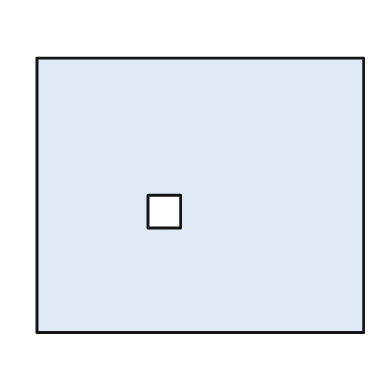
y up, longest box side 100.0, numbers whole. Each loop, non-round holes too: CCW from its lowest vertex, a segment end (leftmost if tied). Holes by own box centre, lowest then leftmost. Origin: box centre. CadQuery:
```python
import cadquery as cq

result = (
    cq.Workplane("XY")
    .moveTo(-50.0, -42.0)
    .lineTo(50.0, -42.0)
    .lineTo(50.0, 42.0)
    .lineTo(-50.0, 42.0)
    .close()
    .moveTo(-16.0, -10.0)
    .lineTo(-6.0, -10.0)
    .lineTo(-6.0, 0.0)
    .lineTo(-16.0, 0.0)
    .close()
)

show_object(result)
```